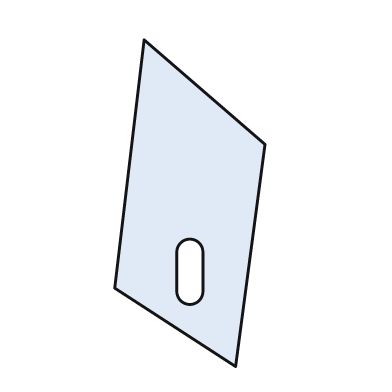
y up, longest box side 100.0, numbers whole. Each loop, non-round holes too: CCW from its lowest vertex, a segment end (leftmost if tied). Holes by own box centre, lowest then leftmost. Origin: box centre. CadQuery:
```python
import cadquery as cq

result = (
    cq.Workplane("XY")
    .moveTo(14.0, -50.0)
    .lineTo(23.0, 18.0)
    .lineTo(-14.0, 50.0)
    .lineTo(-23.0, -26.0)
    .close()
    .moveTo(-4.0, -27.0)
    .threePointArc((0.0, -31.0), (4.0, -27.0))
    .lineTo(4.0, -15.0)
    .threePointArc((0.0, -11.0), (-4.0, -15.0))
    .close()
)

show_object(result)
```